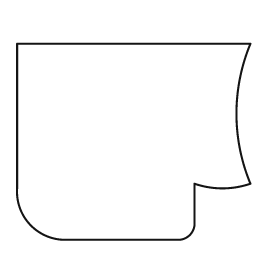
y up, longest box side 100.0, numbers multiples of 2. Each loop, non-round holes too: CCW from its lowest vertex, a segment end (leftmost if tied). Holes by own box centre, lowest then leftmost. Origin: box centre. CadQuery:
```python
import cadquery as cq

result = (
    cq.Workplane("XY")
    .moveTo(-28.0, -42.0)
    .lineTo(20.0, -42.0)
    .threePointArc((24.0, -40.0), (26.0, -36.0))
    .lineTo(26.0, -18.0)
    .threePointArc((38.0, -20.0), (50.0, -18.0))
    .threePointArc((44.0, 12.0), (50.0, 42.0))
    .lineTo(-50.0, 42.0)
    .lineTo(-50.0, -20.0)
    .threePointArc((-44.0, -36.0), (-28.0, -42.0))
    .close()
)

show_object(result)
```